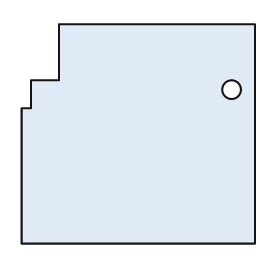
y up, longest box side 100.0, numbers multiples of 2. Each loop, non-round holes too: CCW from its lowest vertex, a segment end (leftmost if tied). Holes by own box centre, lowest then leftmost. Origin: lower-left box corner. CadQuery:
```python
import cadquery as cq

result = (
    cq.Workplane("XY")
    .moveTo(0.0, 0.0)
    .lineTo(100.0, 0.0)
    .lineTo(100.0, 94.0)
    .lineTo(16.0, 94.0)
    .lineTo(16.0, 70.0)
    .lineTo(4.0, 70.0)
    .lineTo(4.0, 58.0)
    .lineTo(0.0, 58.0)
    .close()
    .moveTo(90.0, 66.0)
    .circle(4.0)
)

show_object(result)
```